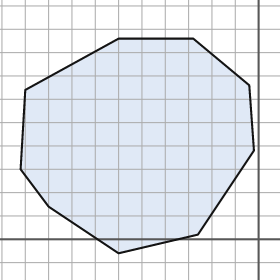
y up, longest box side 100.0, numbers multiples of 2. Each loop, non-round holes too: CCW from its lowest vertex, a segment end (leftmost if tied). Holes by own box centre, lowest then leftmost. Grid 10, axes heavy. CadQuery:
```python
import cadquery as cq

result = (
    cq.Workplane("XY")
    .moveTo(-60.0, -6.0)
    .lineTo(-26.0, 2.0)
    .lineTo(-2.0, 38.0)
    .lineTo(-4.0, 66.0)
    .lineTo(-28.0, 86.0)
    .lineTo(-60.0, 86.0)
    .lineTo(-100.0, 64.0)
    .lineTo(-102.0, 30.0)
    .lineTo(-90.0, 14.0)
    .close()
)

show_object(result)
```